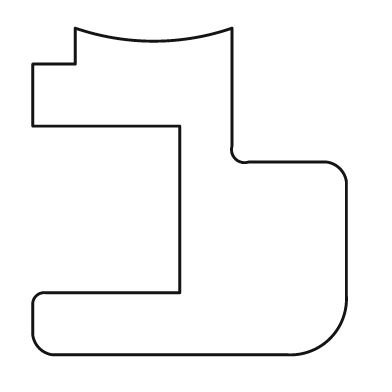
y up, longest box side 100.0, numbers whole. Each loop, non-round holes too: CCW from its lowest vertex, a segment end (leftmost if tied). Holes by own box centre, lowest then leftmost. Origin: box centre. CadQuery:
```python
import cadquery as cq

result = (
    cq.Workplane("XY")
    .moveTo(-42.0, -50.0)
    .lineTo(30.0, -50.0)
    .threePointArc((43.0, -45.0), (48.0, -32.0))
    .lineTo(48.0, 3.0)
    .threePointArc((46.0, 7.0), (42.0, 9.0))
    .lineTo(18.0, 9.0)
    .threePointArc((14.0, 10.0), (13.0, 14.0))
    .lineTo(13.0, 50.0)
    .threePointArc((-11.0, 46.0), (-35.0, 50.0))
    .lineTo(-35.0, 39.0)
    .lineTo(-48.0, 39.0)
    .lineTo(-48.0, 20.0)
    .lineTo(-3.0, 20.0)
    .lineTo(-3.0, -31.0)
    .lineTo(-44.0, -31.0)
    .threePointArc((-47.0, -32.0), (-48.0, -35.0))
    .lineTo(-48.0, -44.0)
    .threePointArc((-46.0, -48.0), (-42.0, -50.0))
    .close()
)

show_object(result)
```